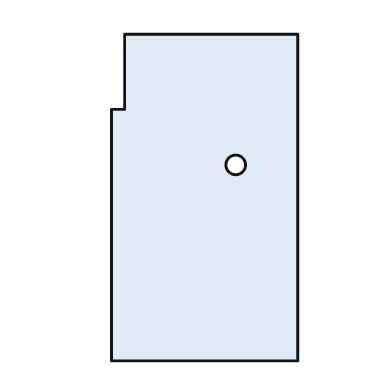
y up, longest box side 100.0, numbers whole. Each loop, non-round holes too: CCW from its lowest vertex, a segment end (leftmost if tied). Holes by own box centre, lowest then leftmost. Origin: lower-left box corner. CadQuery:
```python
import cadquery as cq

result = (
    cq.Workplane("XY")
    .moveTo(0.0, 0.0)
    .lineTo(57.0, 0.0)
    .lineTo(57.0, 100.0)
    .lineTo(4.0, 100.0)
    .lineTo(4.0, 77.0)
    .lineTo(0.0, 77.0)
    .close()
    .moveTo(38.0, 60.0)
    .circle(3.0)
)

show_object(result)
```